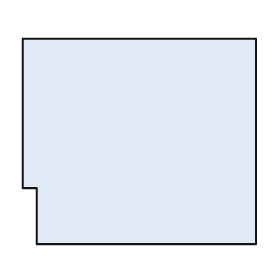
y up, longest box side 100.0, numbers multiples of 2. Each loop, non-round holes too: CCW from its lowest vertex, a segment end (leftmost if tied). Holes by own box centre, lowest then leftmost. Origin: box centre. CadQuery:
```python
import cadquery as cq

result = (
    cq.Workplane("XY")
    .moveTo(-44.0, -44.0)
    .lineTo(50.0, -44.0)
    .lineTo(50.0, 44.0)
    .lineTo(-50.0, 44.0)
    .lineTo(-50.0, -20.0)
    .lineTo(-44.0, -20.0)
    .close()
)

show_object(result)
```